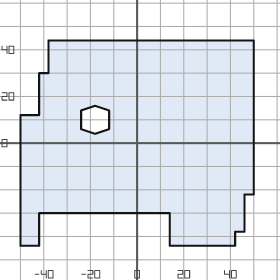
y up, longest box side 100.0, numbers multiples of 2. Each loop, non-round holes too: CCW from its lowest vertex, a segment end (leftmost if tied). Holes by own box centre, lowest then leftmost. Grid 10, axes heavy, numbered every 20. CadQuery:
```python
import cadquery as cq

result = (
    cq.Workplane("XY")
    .moveTo(-50.0, -44.0)
    .lineTo(-42.0, -44.0)
    .lineTo(-42.0, -30.0)
    .lineTo(14.0, -30.0)
    .lineTo(14.0, -44.0)
    .lineTo(42.0, -44.0)
    .lineTo(42.0, -38.0)
    .lineTo(46.0, -38.0)
    .lineTo(46.0, -22.0)
    .lineTo(50.0, -22.0)
    .lineTo(50.0, 44.0)
    .lineTo(-38.0, 44.0)
    .lineTo(-38.0, 30.0)
    .lineTo(-42.0, 30.0)
    .lineTo(-42.0, 12.0)
    .lineTo(-50.0, 12.0)
    .close()
    .moveTo(-18.0, 4.0)
    .lineTo(-12.0, 6.0)
    .lineTo(-12.0, 14.0)
    .lineTo(-18.0, 16.0)
    .lineTo(-24.0, 14.0)
    .lineTo(-24.0, 6.0)
    .close()
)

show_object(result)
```